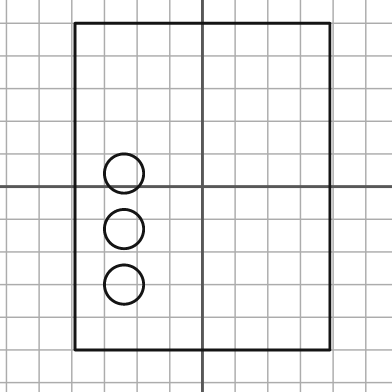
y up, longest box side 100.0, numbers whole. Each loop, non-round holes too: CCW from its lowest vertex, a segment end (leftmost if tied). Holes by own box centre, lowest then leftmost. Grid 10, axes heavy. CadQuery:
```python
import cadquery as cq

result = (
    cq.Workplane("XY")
    .moveTo(-39.0, -50.0)
    .lineTo(39.0, -50.0)
    .lineTo(39.0, 50.0)
    .lineTo(-39.0, 50.0)
    .close()
    .moveTo(-24.0, -30.0)
    .circle(6.0)
    .moveTo(-24.0, -13.0)
    .circle(6.0)
    .moveTo(-24.0, 4.0)
    .circle(6.0)
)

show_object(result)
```